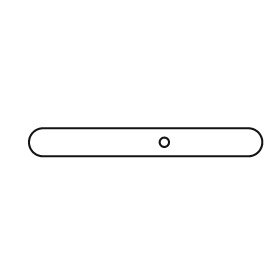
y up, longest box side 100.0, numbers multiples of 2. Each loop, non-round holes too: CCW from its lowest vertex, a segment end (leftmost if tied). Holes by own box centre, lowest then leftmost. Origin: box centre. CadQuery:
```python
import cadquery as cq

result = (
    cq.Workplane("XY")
    .moveTo(-44.0, -6.0)
    .lineTo(44.0, -6.0)
    .threePointArc((50.0, 0.0), (44.0, 6.0))
    .lineTo(-44.0, 6.0)
    .threePointArc((-50.0, 0.0), (-44.0, -6.0))
    .close()
    .moveTo(8.0, 0.0)
    .circle(2.0)
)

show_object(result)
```